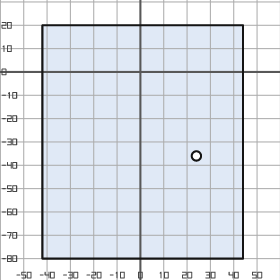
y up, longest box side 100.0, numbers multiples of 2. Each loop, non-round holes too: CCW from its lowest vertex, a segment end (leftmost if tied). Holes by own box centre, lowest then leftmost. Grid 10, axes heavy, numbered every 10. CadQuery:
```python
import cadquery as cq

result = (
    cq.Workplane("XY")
    .moveTo(-42.0, -80.0)
    .lineTo(44.0, -80.0)
    .lineTo(44.0, 20.0)
    .lineTo(-42.0, 20.0)
    .close()
    .moveTo(24.0, -36.0)
    .circle(2.0)
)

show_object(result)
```